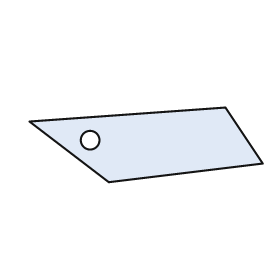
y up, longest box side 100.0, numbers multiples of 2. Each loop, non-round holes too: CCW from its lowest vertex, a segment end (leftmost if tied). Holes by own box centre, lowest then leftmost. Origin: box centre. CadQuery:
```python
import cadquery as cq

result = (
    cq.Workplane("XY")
    .moveTo(-16.0, -16.0)
    .lineTo(50.0, -8.0)
    .lineTo(34.0, 16.0)
    .lineTo(-50.0, 10.0)
    .close()
    .moveTo(-24.0, 2.0)
    .circle(4.0)
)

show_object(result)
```